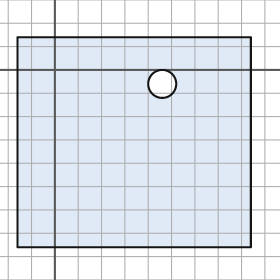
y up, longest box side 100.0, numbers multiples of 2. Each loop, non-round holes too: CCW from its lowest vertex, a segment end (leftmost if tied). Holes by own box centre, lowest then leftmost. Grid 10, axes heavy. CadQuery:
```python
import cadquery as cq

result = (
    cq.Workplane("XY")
    .moveTo(-16.0, -76.0)
    .lineTo(84.0, -76.0)
    .lineTo(84.0, 14.0)
    .lineTo(-16.0, 14.0)
    .close()
    .moveTo(46.0, -6.0)
    .circle(6.0)
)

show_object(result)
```